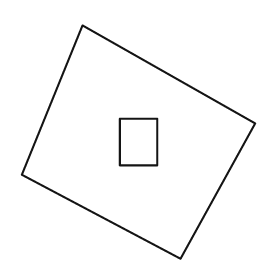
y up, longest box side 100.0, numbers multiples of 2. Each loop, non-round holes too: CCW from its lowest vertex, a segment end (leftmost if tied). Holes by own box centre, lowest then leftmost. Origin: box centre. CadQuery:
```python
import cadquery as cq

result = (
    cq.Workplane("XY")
    .moveTo(18.0, -50.0)
    .lineTo(50.0, 8.0)
    .lineTo(-24.0, 50.0)
    .lineTo(-50.0, -14.0)
    .close()
    .moveTo(-8.0, -10.0)
    .lineTo(8.0, -10.0)
    .lineTo(8.0, 10.0)
    .lineTo(-8.0, 10.0)
    .close()
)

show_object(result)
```